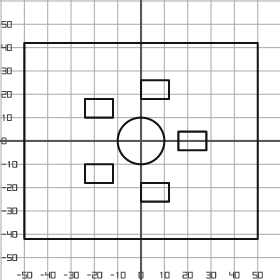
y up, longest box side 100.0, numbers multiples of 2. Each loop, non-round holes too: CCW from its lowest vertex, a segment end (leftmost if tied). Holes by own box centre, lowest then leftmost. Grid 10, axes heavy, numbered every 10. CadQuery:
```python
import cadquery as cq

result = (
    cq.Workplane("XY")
    .moveTo(-50.0, -42.0)
    .lineTo(50.0, -42.0)
    .lineTo(50.0, 42.0)
    .lineTo(-50.0, 42.0)
    .close()
    .moveTo(0.0, -26.0)
    .lineTo(12.0, -26.0)
    .lineTo(12.0, -18.0)
    .lineTo(0.0, -18.0)
    .close()
    .moveTo(-24.0, -18.0)
    .lineTo(-12.0, -18.0)
    .lineTo(-12.0, -10.0)
    .lineTo(-24.0, -10.0)
    .close()
    .moveTo(0.0, 0.0)
    .circle(10.0)
    .moveTo(16.0, -4.0)
    .lineTo(28.0, -4.0)
    .lineTo(28.0, 4.0)
    .lineTo(16.0, 4.0)
    .close()
    .moveTo(-24.0, 10.0)
    .lineTo(-12.0, 10.0)
    .lineTo(-12.0, 18.0)
    .lineTo(-24.0, 18.0)
    .close()
    .moveTo(0.0, 18.0)
    .lineTo(12.0, 18.0)
    .lineTo(12.0, 26.0)
    .lineTo(0.0, 26.0)
    .close()
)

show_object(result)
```